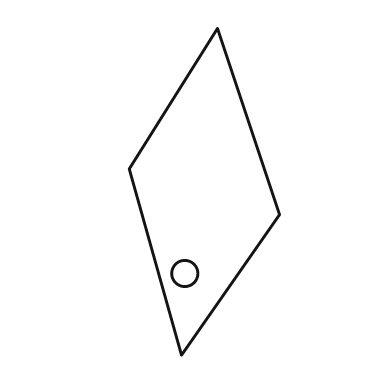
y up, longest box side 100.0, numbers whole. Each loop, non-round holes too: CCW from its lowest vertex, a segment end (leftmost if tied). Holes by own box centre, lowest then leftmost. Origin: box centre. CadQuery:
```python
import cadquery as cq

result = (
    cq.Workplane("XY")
    .moveTo(-7.0, -50.0)
    .lineTo(23.0, -7.0)
    .lineTo(4.0, 50.0)
    .lineTo(-23.0, 7.0)
    .close()
    .moveTo(-6.0, -25.0)
    .circle(4.0)
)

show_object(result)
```